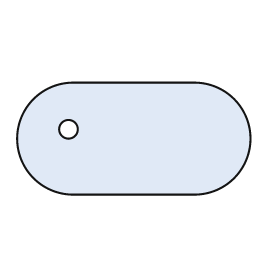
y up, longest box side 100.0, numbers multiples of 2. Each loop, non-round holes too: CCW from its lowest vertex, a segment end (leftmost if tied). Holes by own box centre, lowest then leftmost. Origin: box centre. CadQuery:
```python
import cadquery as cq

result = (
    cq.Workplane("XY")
    .moveTo(-26.0, -24.0)
    .lineTo(26.0, -24.0)
    .threePointArc((50.0, 0.0), (26.0, 24.0))
    .lineTo(-26.0, 24.0)
    .threePointArc((-50.0, 0.0), (-26.0, -24.0))
    .close()
    .moveTo(-28.0, 4.0)
    .circle(4.0)
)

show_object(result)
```